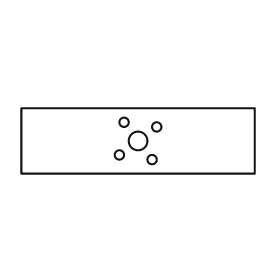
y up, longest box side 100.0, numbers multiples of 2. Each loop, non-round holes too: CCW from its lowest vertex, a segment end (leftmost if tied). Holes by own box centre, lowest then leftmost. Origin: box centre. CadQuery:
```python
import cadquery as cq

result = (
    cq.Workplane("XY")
    .moveTo(-50.0, -14.0)
    .lineTo(50.0, -14.0)
    .lineTo(50.0, 14.0)
    .lineTo(-50.0, 14.0)
    .close()
    .moveTo(6.0, -8.0)
    .circle(2.0)
    .moveTo(-8.0, -6.0)
    .circle(2.0)
    .moveTo(0.0, 0.0)
    .circle(4.0)
    .moveTo(8.0, 6.0)
    .circle(2.0)
    .moveTo(-6.0, 8.0)
    .circle(2.0)
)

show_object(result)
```